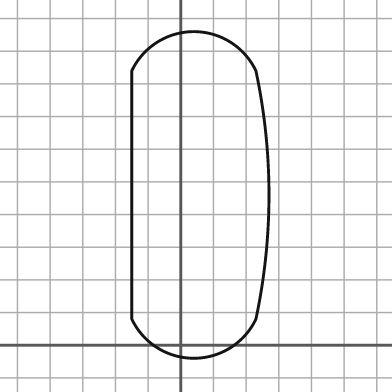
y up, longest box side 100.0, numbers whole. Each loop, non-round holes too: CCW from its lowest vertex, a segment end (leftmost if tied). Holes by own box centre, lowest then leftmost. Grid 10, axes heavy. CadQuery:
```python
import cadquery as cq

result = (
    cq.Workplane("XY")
    .moveTo(-15.0, 8.0)
    .threePointArc((4.0, -4.0), (23.0, 8.0))
    .threePointArc((27.0, 46.0), (23.0, 84.0))
    .threePointArc((4.0, 96.0), (-15.0, 84.0))
    .close()
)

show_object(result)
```